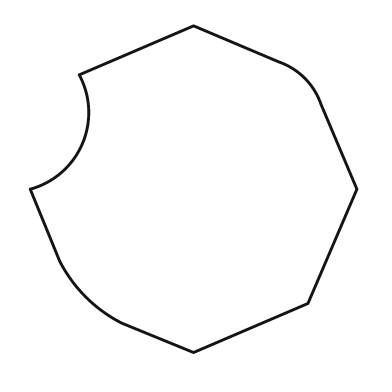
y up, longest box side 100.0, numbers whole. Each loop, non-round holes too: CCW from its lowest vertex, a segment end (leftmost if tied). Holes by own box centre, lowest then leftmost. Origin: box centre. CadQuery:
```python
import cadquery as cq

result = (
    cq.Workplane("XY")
    .moveTo(0.0, -50.0)
    .lineTo(35.0, -35.0)
    .lineTo(50.0, 0.0)
    .lineTo(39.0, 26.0)
    .threePointArc((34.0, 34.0), (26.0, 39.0))
    .lineTo(0.0, 50.0)
    .lineTo(-35.0, 35.0)
    .threePointArc((-34.0, 14.0), (-50.0, 0.0))
    .lineTo(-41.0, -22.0)
    .threePointArc((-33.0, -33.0), (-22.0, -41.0))
    .close()
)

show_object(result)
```